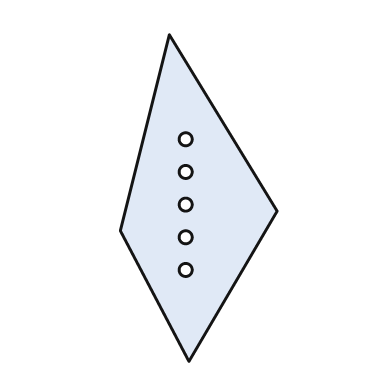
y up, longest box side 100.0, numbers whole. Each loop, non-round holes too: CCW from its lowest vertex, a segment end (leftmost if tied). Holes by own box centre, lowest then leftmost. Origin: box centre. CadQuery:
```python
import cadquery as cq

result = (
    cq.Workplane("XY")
    .moveTo(-3.0, -50.0)
    .lineTo(24.0, -4.0)
    .lineTo(-9.0, 50.0)
    .lineTo(-24.0, -10.0)
    .close()
    .moveTo(-4.0, -22.0)
    .circle(2.0)
    .moveTo(-4.0, -12.0)
    .circle(2.0)
    .moveTo(-4.0, -2.0)
    .circle(2.0)
    .moveTo(-4.0, 8.0)
    .circle(2.0)
    .moveTo(-4.0, 18.0)
    .circle(2.0)
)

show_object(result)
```